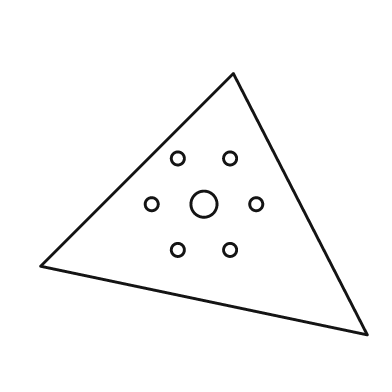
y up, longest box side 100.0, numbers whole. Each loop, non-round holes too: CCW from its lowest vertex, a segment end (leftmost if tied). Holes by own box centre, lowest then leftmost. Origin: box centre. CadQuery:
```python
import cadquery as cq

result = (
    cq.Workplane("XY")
    .moveTo(50.0, -40.0)
    .lineTo(9.0, 40.0)
    .lineTo(-50.0, -19.0)
    .close()
    .moveTo(-8.0, -14.0)
    .circle(2.0)
    .moveTo(8.0, -14.0)
    .circle(2.0)
    .moveTo(-16.0, 0.0)
    .circle(2.0)
    .moveTo(0.0, 0.0)
    .circle(4.0)
    .moveTo(16.0, 0.0)
    .circle(2.0)
    .moveTo(-8.0, 14.0)
    .circle(2.0)
    .moveTo(8.0, 14.0)
    .circle(2.0)
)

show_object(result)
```